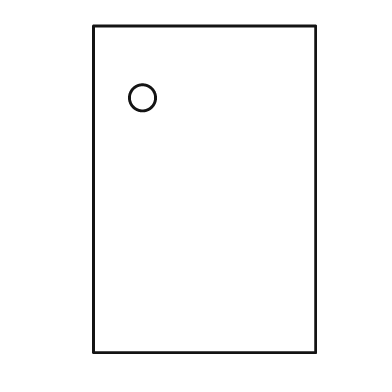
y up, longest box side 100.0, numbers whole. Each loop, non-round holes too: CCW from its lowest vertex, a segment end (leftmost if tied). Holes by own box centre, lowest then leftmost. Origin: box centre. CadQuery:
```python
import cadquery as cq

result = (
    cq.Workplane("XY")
    .moveTo(-34.0, -50.0)
    .lineTo(34.0, -50.0)
    .lineTo(34.0, 50.0)
    .lineTo(-34.0, 50.0)
    .close()
    .moveTo(-19.0, 28.0)
    .circle(4.0)
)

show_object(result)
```